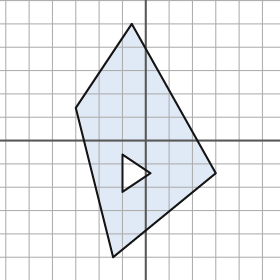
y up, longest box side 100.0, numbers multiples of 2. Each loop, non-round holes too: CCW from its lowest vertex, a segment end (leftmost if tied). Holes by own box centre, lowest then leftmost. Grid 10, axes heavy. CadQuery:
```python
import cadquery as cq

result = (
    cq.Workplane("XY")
    .moveTo(-14.0, -50.0)
    .lineTo(30.0, -14.0)
    .lineTo(-6.0, 50.0)
    .lineTo(-30.0, 14.0)
    .close()
    .moveTo(-10.0, -22.0)
    .lineTo(2.0, -14.0)
    .lineTo(-10.0, -6.0)
    .close()
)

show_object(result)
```